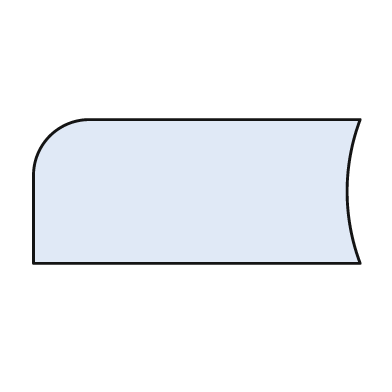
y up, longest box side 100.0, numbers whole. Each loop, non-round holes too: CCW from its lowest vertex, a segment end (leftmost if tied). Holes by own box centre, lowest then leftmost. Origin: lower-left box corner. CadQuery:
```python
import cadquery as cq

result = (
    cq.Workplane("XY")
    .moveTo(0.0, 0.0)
    .lineTo(100.0, 0.0)
    .threePointArc((96.0, 22.0), (100.0, 44.0))
    .lineTo(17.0, 44.0)
    .threePointArc((5.0, 39.0), (0.0, 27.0))
    .close()
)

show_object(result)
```